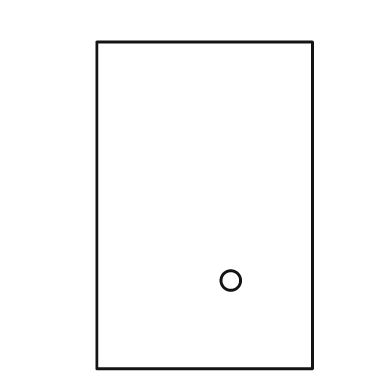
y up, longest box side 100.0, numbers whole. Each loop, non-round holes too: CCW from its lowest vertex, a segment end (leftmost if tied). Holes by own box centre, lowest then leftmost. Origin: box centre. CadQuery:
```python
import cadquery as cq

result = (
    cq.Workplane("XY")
    .moveTo(-33.0, -50.0)
    .lineTo(33.0, -50.0)
    .lineTo(33.0, 50.0)
    .lineTo(-33.0, 50.0)
    .close()
    .moveTo(8.0, -23.0)
    .circle(3.0)
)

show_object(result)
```